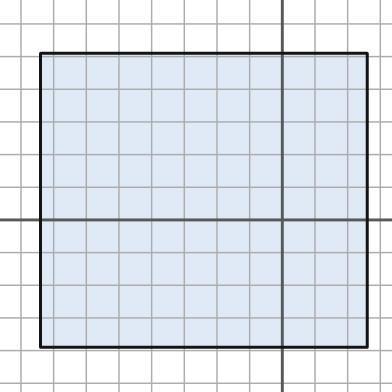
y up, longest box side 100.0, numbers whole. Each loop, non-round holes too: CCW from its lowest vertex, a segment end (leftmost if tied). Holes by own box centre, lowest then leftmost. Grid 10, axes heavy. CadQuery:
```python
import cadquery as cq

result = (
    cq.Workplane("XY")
    .moveTo(-74.0, -39.0)
    .lineTo(26.0, -39.0)
    .lineTo(26.0, 51.0)
    .lineTo(-74.0, 51.0)
    .close()
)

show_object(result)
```